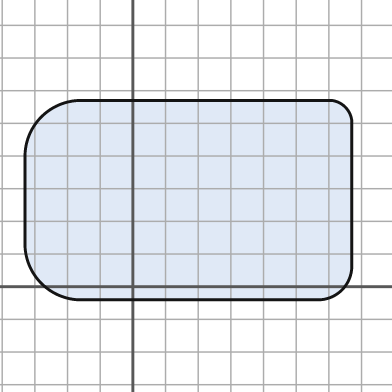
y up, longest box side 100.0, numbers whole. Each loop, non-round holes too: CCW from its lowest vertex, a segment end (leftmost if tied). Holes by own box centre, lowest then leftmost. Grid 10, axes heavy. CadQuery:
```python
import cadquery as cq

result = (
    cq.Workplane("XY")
    .moveTo(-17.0, -4.0)
    .lineTo(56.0, -4.0)
    .threePointArc((64.0, -1.0), (67.0, 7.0))
    .lineTo(67.0, 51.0)
    .threePointArc((65.0, 55.0), (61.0, 57.0))
    .lineTo(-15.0, 57.0)
    .threePointArc((-28.0, 52.0), (-33.0, 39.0))
    .lineTo(-33.0, 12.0)
    .threePointArc((-28.0, 1.0), (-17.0, -4.0))
    .close()
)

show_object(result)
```